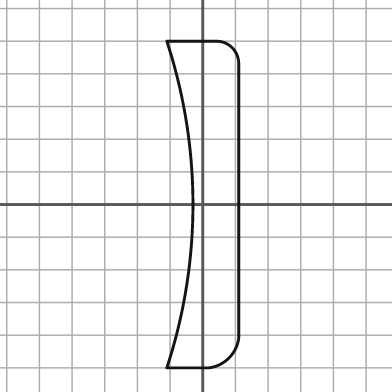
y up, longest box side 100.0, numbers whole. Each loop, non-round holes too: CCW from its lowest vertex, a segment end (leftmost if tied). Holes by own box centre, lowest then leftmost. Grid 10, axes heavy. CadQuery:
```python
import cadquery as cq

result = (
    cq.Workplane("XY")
    .moveTo(-11.0, -50.0)
    .lineTo(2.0, -50.0)
    .threePointArc((8.0, -47.0), (11.0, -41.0))
    .lineTo(11.0, 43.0)
    .threePointArc((9.0, 48.0), (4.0, 50.0))
    .lineTo(-11.0, 50.0)
    .threePointArc((-3.0, 0.0), (-11.0, -50.0))
    .close()
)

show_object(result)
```